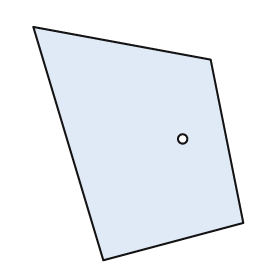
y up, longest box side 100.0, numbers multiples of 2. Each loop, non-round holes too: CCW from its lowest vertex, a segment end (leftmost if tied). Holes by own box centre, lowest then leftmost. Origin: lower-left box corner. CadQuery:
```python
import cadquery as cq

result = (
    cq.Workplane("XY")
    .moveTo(30.0, 0.0)
    .lineTo(90.0, 16.0)
    .lineTo(76.0, 86.0)
    .lineTo(0.0, 100.0)
    .close()
    .moveTo(64.0, 52.0)
    .circle(2.0)
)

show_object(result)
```